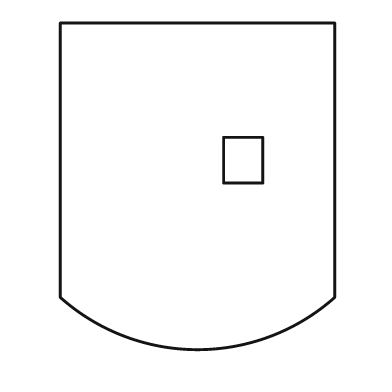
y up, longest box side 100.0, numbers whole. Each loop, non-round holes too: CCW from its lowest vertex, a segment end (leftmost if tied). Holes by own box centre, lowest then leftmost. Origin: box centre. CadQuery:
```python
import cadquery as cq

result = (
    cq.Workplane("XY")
    .moveTo(-42.0, -34.0)
    .threePointArc((0.0, -50.0), (42.0, -34.0))
    .lineTo(42.0, 50.0)
    .lineTo(-42.0, 50.0)
    .close()
    .moveTo(8.0, 1.0)
    .lineTo(20.0, 1.0)
    .lineTo(20.0, 15.0)
    .lineTo(8.0, 15.0)
    .close()
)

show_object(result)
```